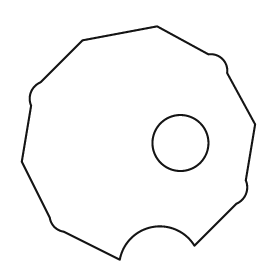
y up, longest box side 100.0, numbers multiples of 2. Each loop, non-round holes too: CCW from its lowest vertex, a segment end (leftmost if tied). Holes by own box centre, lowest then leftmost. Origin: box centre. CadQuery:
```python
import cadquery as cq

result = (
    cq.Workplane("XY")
    .moveTo(-8.0, -50.0)
    .threePointArc((6.0, -36.0), (24.0, -44.0))
    .lineTo(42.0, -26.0)
    .threePointArc((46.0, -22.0), (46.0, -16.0))
    .lineTo(50.0, 8.0)
    .lineTo(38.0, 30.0)
    .threePointArc((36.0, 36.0), (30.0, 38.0))
    .lineTo(8.0, 50.0)
    .lineTo(-24.0, 44.0)
    .lineTo(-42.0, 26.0)
    .threePointArc((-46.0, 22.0), (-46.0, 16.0))
    .lineTo(-50.0, -8.0)
    .lineTo(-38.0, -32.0)
    .threePointArc((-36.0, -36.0), (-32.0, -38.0))
    .close()
    .moveTo(18.0, 0.0)
    .circle(12.0)
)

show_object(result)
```